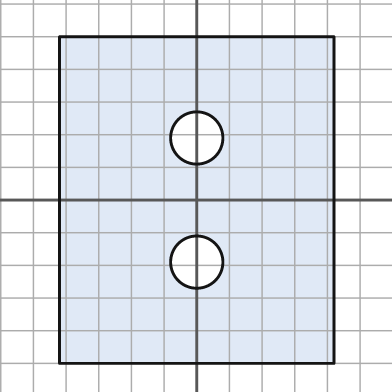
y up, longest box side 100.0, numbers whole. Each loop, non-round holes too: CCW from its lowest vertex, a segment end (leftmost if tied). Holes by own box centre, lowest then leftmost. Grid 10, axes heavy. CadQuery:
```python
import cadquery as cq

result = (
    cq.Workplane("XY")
    .moveTo(-42.0, -50.0)
    .lineTo(42.0, -50.0)
    .lineTo(42.0, 50.0)
    .lineTo(-42.0, 50.0)
    .close()
    .moveTo(0.0, -19.0)
    .circle(8.0)
    .moveTo(0.0, 19.0)
    .circle(8.0)
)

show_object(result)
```